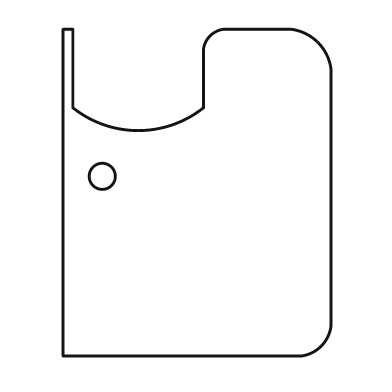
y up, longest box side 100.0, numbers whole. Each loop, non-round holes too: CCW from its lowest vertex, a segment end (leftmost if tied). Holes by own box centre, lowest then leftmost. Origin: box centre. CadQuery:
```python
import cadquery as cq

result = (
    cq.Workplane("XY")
    .moveTo(-41.0, -50.0)
    .lineTo(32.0, -50.0)
    .threePointArc((38.0, -47.0), (41.0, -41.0))
    .lineTo(41.0, 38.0)
    .threePointArc((37.0, 46.0), (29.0, 50.0))
    .lineTo(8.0, 50.0)
    .threePointArc((4.0, 48.0), (2.0, 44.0))
    .lineTo(2.0, 26.0)
    .threePointArc((-18.0, 19.0), (-38.0, 26.0))
    .lineTo(-38.0, 50.0)
    .lineTo(-41.0, 50.0)
    .close()
    .moveTo(-29.0, 5.0)
    .circle(4.0)
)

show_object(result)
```